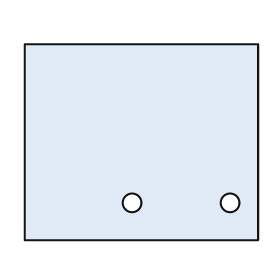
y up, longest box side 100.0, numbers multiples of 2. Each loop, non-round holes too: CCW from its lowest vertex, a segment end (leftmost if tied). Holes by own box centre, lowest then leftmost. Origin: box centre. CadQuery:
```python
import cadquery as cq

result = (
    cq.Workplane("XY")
    .moveTo(-50.0, -42.0)
    .lineTo(50.0, -42.0)
    .lineTo(50.0, 42.0)
    .lineTo(-50.0, 42.0)
    .close()
    .moveTo(-4.0, -26.0)
    .circle(4.0)
    .moveTo(38.0, -26.0)
    .circle(4.0)
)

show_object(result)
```